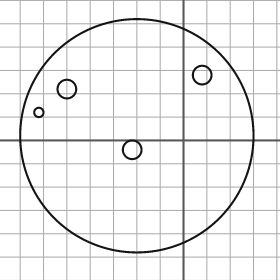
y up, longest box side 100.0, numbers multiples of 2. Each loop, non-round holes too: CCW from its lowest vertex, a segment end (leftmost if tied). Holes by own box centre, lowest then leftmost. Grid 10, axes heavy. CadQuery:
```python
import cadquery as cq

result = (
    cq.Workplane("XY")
    .moveTo(-20.0, 2.0)
    .circle(50.0)
    .moveTo(-22.0, -4.0)
    .circle(4.0)
    .moveTo(-62.0, 12.0)
    .circle(2.0)
    .moveTo(-50.0, 22.0)
    .circle(4.0)
    .moveTo(8.0, 28.0)
    .circle(4.0)
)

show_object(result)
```